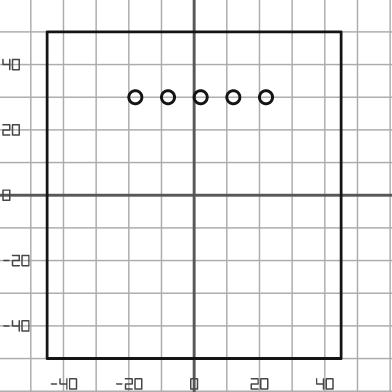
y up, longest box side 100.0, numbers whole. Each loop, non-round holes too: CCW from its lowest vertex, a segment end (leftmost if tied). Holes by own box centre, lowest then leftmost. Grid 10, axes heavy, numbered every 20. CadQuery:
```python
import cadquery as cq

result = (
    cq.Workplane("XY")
    .moveTo(-45.0, -50.0)
    .lineTo(45.0, -50.0)
    .lineTo(45.0, 50.0)
    .lineTo(-45.0, 50.0)
    .close()
    .moveTo(-18.0, 30.0)
    .circle(2.0)
    .moveTo(-8.0, 30.0)
    .circle(2.0)
    .moveTo(2.0, 30.0)
    .circle(2.0)
    .moveTo(12.0, 30.0)
    .circle(2.0)
    .moveTo(22.0, 30.0)
    .circle(2.0)
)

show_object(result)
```